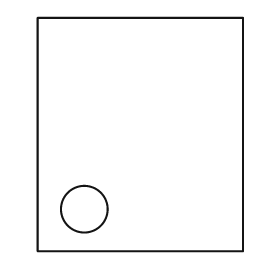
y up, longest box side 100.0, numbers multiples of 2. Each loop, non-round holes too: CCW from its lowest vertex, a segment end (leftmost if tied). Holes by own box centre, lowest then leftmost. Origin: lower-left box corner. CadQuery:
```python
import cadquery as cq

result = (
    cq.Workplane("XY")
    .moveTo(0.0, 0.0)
    .lineTo(88.0, 0.0)
    .lineTo(88.0, 100.0)
    .lineTo(0.0, 100.0)
    .close()
    .moveTo(20.0, 18.0)
    .circle(10.0)
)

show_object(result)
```